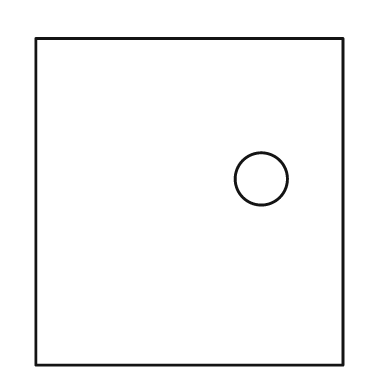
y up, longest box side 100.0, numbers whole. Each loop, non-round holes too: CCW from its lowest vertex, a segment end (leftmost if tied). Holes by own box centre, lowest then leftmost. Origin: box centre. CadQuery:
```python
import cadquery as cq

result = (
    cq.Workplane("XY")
    .moveTo(-47.0, -50.0)
    .lineTo(47.0, -50.0)
    .lineTo(47.0, 50.0)
    .lineTo(-47.0, 50.0)
    .close()
    .moveTo(22.0, 7.0)
    .circle(8.0)
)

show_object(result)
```